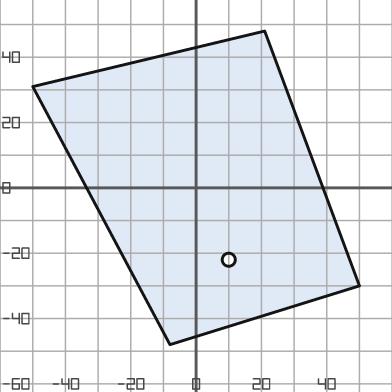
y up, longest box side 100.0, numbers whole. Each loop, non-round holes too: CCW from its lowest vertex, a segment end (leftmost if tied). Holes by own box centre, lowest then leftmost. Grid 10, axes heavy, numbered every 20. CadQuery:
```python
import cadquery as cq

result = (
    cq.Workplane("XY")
    .moveTo(-8.0, -48.0)
    .lineTo(50.0, -30.0)
    .lineTo(21.0, 48.0)
    .lineTo(-50.0, 31.0)
    .close()
    .moveTo(10.0, -22.0)
    .circle(2.0)
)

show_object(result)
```